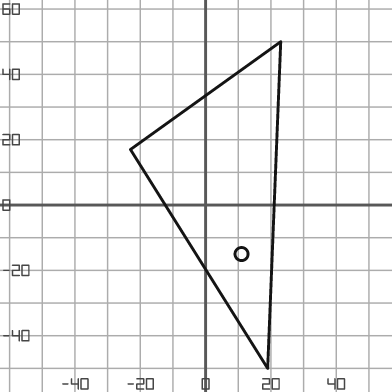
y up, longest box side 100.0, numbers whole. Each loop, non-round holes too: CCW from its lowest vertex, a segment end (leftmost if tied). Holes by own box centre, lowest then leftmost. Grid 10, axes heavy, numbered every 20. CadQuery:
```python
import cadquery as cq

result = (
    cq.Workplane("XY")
    .moveTo(19.0, -50.0)
    .lineTo(23.0, 50.0)
    .lineTo(-23.0, 17.0)
    .close()
    .moveTo(11.0, -15.0)
    .circle(2.0)
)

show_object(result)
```